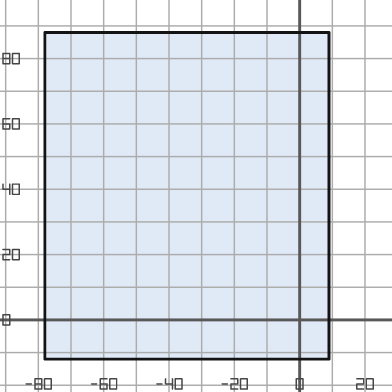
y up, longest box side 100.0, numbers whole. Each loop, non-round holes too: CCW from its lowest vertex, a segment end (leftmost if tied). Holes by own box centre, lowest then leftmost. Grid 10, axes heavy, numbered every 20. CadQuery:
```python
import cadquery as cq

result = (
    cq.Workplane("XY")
    .moveTo(-78.0, -12.0)
    .lineTo(9.0, -12.0)
    .lineTo(9.0, 88.0)
    .lineTo(-78.0, 88.0)
    .close()
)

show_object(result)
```